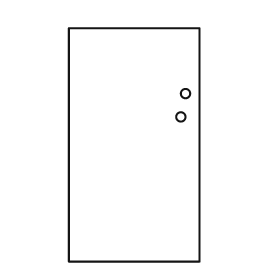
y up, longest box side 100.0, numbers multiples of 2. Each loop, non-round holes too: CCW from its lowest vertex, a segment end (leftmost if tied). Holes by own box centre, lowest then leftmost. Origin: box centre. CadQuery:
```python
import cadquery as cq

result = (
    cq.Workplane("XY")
    .moveTo(-28.0, -50.0)
    .lineTo(28.0, -50.0)
    .lineTo(28.0, 50.0)
    .lineTo(-28.0, 50.0)
    .close()
    .moveTo(20.0, 12.0)
    .circle(2.0)
    .moveTo(22.0, 22.0)
    .circle(2.0)
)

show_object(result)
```